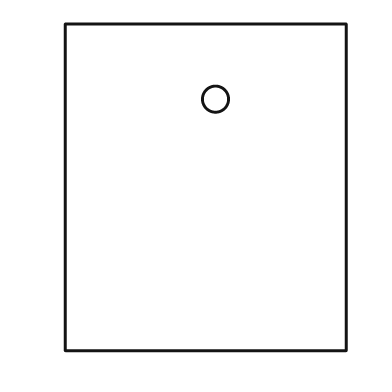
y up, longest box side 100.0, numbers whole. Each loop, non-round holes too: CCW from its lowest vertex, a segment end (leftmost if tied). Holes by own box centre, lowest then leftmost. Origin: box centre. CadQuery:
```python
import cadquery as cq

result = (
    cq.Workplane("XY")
    .moveTo(-43.0, -50.0)
    .lineTo(43.0, -50.0)
    .lineTo(43.0, 50.0)
    .lineTo(-43.0, 50.0)
    .close()
    .moveTo(3.0, 27.0)
    .circle(4.0)
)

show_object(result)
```